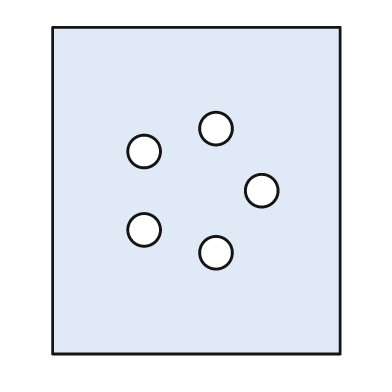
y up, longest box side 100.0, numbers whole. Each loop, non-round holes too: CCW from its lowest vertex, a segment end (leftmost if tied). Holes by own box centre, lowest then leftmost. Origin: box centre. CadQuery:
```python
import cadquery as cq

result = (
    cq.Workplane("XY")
    .moveTo(-44.0, -50.0)
    .lineTo(44.0, -50.0)
    .lineTo(44.0, 50.0)
    .lineTo(-44.0, 50.0)
    .close()
    .moveTo(6.0, -19.0)
    .circle(5.0)
    .moveTo(-16.0, -12.0)
    .circle(5.0)
    .moveTo(20.0, 0.0)
    .circle(5.0)
    .moveTo(-16.0, 12.0)
    .circle(5.0)
    .moveTo(6.0, 19.0)
    .circle(5.0)
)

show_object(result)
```